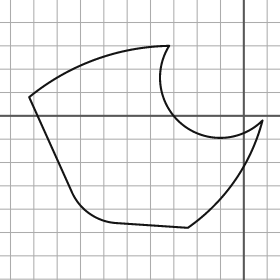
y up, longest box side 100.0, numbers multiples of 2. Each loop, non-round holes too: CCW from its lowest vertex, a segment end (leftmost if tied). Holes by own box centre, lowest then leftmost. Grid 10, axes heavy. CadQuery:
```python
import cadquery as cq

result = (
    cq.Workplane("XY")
    .moveTo(-24.0, -48.0)
    .threePointArc((-4.0, -28.0), (8.0, -2.0))
    .threePointArc((-26.0, -4.0), (-32.0, 30.0))
    .threePointArc((-64.0, 24.0), (-92.0, 8.0))
    .lineTo(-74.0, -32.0)
    .threePointArc((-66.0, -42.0), (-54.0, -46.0))
    .close()
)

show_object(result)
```